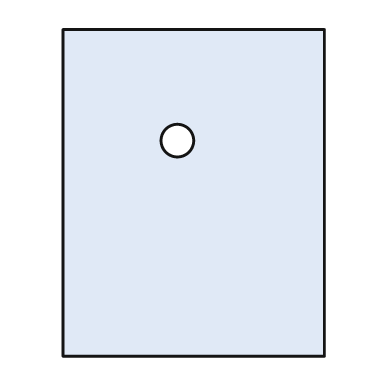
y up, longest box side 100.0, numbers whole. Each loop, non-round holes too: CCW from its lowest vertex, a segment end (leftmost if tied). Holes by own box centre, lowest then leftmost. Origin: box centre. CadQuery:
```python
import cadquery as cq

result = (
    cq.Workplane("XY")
    .moveTo(-40.0, -50.0)
    .lineTo(40.0, -50.0)
    .lineTo(40.0, 50.0)
    .lineTo(-40.0, 50.0)
    .close()
    .moveTo(-5.0, 16.0)
    .circle(5.0)
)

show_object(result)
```